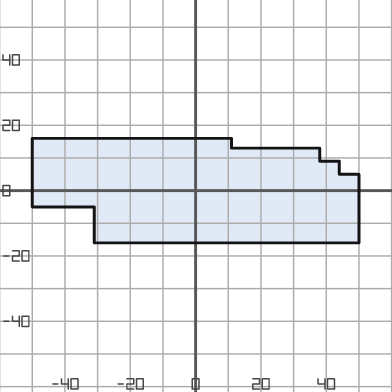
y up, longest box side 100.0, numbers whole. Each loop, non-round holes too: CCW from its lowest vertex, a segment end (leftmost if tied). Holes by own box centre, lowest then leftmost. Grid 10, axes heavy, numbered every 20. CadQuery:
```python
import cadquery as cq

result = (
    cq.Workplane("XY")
    .moveTo(-31.0, -16.0)
    .lineTo(50.0, -16.0)
    .lineTo(50.0, 5.0)
    .lineTo(44.0, 5.0)
    .lineTo(44.0, 9.0)
    .lineTo(38.0, 9.0)
    .lineTo(38.0, 13.0)
    .lineTo(11.0, 13.0)
    .lineTo(11.0, 16.0)
    .lineTo(-50.0, 16.0)
    .lineTo(-50.0, -5.0)
    .lineTo(-31.0, -5.0)
    .close()
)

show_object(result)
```